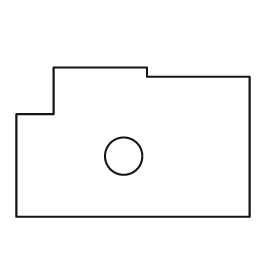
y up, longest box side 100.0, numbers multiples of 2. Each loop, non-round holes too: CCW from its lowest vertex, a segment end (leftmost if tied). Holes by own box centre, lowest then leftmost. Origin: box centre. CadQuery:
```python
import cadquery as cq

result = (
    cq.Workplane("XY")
    .moveTo(-50.0, -32.0)
    .lineTo(50.0, -32.0)
    .lineTo(50.0, 28.0)
    .lineTo(6.0, 28.0)
    .lineTo(6.0, 32.0)
    .lineTo(-34.0, 32.0)
    .lineTo(-34.0, 12.0)
    .lineTo(-50.0, 12.0)
    .close()
    .moveTo(-4.0, -6.0)
    .circle(8.0)
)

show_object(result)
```